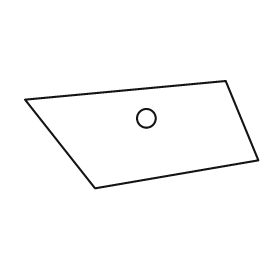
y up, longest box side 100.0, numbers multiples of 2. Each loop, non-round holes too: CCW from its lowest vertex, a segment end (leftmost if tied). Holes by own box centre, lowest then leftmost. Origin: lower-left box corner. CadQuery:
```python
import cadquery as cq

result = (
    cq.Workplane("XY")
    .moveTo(30.0, 0.0)
    .lineTo(100.0, 12.0)
    .lineTo(86.0, 46.0)
    .lineTo(0.0, 38.0)
    .close()
    .moveTo(52.0, 30.0)
    .circle(4.0)
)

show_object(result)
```